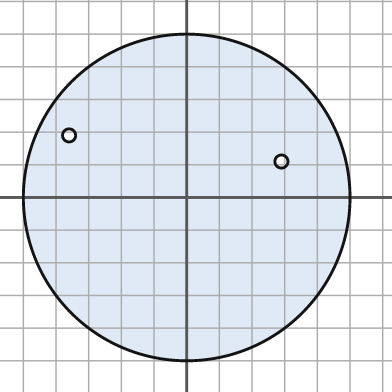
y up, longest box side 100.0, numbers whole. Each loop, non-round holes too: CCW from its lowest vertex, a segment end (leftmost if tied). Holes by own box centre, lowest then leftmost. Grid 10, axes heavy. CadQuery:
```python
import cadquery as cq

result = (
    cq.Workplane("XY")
    .moveTo(0.0, 0.0)
    .circle(50.0)
    .moveTo(29.0, 11.0)
    .circle(2.0)
    .moveTo(-36.0, 19.0)
    .circle(2.0)
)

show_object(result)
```